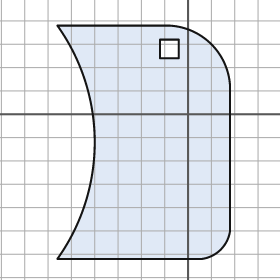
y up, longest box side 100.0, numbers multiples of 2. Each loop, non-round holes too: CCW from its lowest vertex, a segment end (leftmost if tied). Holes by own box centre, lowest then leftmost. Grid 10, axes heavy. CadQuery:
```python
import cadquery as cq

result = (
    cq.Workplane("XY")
    .moveTo(-56.0, -62.0)
    .lineTo(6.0, -62.0)
    .threePointArc((14.0, -58.0), (18.0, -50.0))
    .lineTo(18.0, 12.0)
    .threePointArc((10.0, 30.0), (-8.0, 38.0))
    .lineTo(-56.0, 38.0)
    .threePointArc((-40.0, -12.0), (-56.0, -62.0))
    .close()
    .moveTo(-12.0, 24.0)
    .lineTo(-4.0, 24.0)
    .lineTo(-4.0, 32.0)
    .lineTo(-12.0, 32.0)
    .close()
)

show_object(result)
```